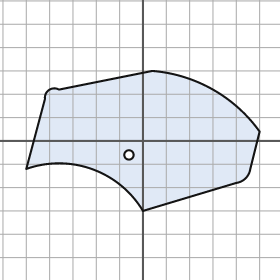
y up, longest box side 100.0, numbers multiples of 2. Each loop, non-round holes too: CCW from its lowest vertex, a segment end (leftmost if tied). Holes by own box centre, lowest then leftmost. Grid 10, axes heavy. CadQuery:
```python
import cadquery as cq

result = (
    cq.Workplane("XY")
    .moveTo(0.0, -30.0)
    .lineTo(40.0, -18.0)
    .threePointArc((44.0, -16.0), (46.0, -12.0))
    .lineTo(50.0, 4.0)
    .threePointArc((30.0, 22.0), (4.0, 30.0))
    .lineTo(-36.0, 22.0)
    .threePointArc((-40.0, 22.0), (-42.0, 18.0))
    .lineTo(-50.0, -12.0)
    .threePointArc((-22.0, -12.0), (0.0, -30.0))
    .close()
    .moveTo(-6.0, -6.0)
    .circle(2.0)
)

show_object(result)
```